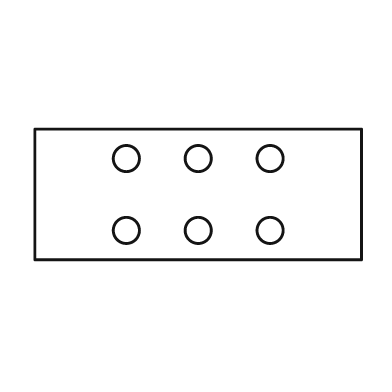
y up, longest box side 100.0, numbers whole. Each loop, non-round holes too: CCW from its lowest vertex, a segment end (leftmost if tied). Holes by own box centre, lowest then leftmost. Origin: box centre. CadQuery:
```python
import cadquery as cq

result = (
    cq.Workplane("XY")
    .moveTo(-50.0, -20.0)
    .lineTo(50.0, -20.0)
    .lineTo(50.0, 20.0)
    .lineTo(-50.0, 20.0)
    .close()
    .moveTo(-22.0, -11.0)
    .circle(4.0)
    .moveTo(0.0, -11.0)
    .circle(4.0)
    .moveTo(22.0, -11.0)
    .circle(4.0)
    .moveTo(-22.0, 11.0)
    .circle(4.0)
    .moveTo(0.0, 11.0)
    .circle(4.0)
    .moveTo(22.0, 11.0)
    .circle(4.0)
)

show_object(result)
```